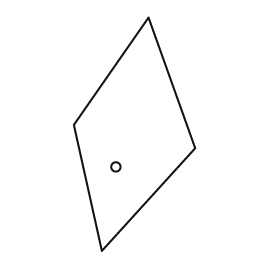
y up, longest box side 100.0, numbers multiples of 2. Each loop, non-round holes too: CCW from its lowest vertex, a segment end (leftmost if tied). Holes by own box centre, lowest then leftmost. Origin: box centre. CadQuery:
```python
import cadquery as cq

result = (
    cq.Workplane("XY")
    .moveTo(-14.0, -50.0)
    .lineTo(26.0, -6.0)
    .lineTo(6.0, 50.0)
    .lineTo(-26.0, 4.0)
    .close()
    .moveTo(-8.0, -14.0)
    .circle(2.0)
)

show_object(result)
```